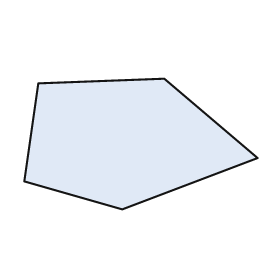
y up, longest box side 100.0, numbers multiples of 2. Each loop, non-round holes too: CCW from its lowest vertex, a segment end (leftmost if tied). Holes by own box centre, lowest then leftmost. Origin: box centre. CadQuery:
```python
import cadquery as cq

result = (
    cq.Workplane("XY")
    .moveTo(-8.0, -28.0)
    .lineTo(50.0, -6.0)
    .lineTo(10.0, 28.0)
    .lineTo(-44.0, 26.0)
    .lineTo(-50.0, -16.0)
    .close()
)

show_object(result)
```